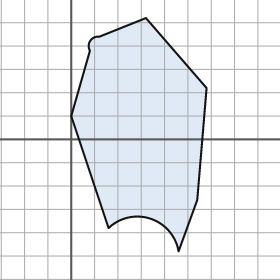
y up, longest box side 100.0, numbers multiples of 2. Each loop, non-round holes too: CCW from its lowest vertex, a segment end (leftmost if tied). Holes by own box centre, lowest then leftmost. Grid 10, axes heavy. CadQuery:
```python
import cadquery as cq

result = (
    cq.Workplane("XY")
    .moveTo(46.0, -48.0)
    .lineTo(54.0, -26.0)
    .lineTo(58.0, 22.0)
    .lineTo(32.0, 52.0)
    .lineTo(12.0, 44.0)
    .threePointArc((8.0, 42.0), (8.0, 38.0))
    .lineTo(0.0, 10.0)
    .lineTo(16.0, -38.0)
    .threePointArc((34.0, -34.0), (46.0, -48.0))
    .close()
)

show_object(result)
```